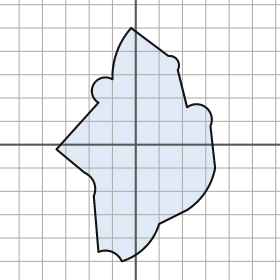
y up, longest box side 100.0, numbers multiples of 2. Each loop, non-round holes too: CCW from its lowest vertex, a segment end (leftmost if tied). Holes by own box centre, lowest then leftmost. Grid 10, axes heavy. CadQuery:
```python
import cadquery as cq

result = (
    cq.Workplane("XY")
    .moveTo(-6.0, -50.0)
    .threePointArc((4.0, -44.0), (10.0, -34.0))
    .lineTo(22.0, -28.0)
    .threePointArc((30.0, -20.0), (34.0, -10.0))
    .lineTo(32.0, 8.0)
    .threePointArc((30.0, 16.0), (22.0, 16.0))
    .lineTo(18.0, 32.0)
    .threePointArc((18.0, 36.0), (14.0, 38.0))
    .lineTo(-2.0, 50.0)
    .threePointArc((-8.0, 40.0), (-10.0, 28.0))
    .threePointArc((-18.0, 26.0), (-16.0, 18.0))
    .lineTo(-34.0, -2.0)
    .lineTo(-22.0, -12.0)
    .threePointArc((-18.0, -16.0), (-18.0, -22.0))
    .lineTo(-16.0, -46.0)
    .threePointArc((-10.0, -46.0), (-6.0, -50.0))
    .close()
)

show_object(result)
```